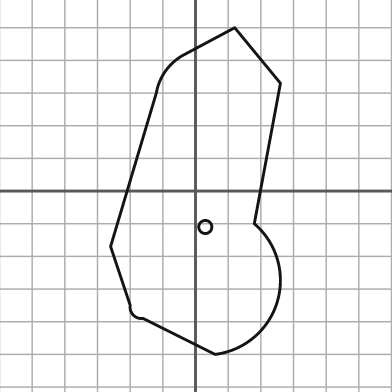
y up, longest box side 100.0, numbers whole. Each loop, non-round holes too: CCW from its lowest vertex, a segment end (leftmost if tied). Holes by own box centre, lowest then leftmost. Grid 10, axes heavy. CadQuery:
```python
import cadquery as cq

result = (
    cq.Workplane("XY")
    .moveTo(6.0, -50.0)
    .threePointArc((25.0, -34.0), (18.0, -10.0))
    .lineTo(26.0, 33.0)
    .lineTo(12.0, 50.0)
    .lineTo(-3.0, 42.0)
    .threePointArc((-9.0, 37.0), (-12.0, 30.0))
    .lineTo(-26.0, -17.0)
    .lineTo(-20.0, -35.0)
    .threePointArc((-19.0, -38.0), (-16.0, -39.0))
    .close()
    .moveTo(3.0, -11.0)
    .circle(2.0)
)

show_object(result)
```